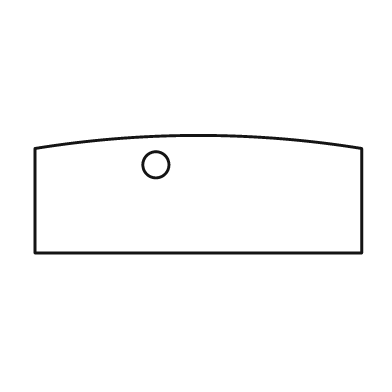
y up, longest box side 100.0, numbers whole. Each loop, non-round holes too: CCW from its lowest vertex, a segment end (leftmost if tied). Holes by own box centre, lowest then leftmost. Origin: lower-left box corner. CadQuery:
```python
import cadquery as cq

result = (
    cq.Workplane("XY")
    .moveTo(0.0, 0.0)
    .lineTo(100.0, 0.0)
    .lineTo(100.0, 32.0)
    .threePointArc((50.0, 36.0), (0.0, 32.0))
    .close()
    .moveTo(37.0, 27.0)
    .circle(4.0)
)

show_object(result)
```